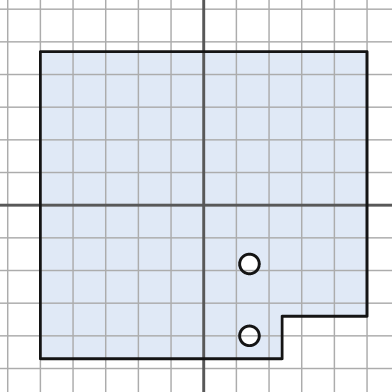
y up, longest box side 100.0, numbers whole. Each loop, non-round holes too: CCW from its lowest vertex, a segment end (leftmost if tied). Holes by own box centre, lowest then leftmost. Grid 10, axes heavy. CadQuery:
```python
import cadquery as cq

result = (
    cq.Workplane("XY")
    .moveTo(-50.0, -47.0)
    .lineTo(24.0, -47.0)
    .lineTo(24.0, -34.0)
    .lineTo(50.0, -34.0)
    .lineTo(50.0, 47.0)
    .lineTo(-50.0, 47.0)
    .close()
    .moveTo(14.0, -40.0)
    .circle(3.0)
    .moveTo(14.0, -18.0)
    .circle(3.0)
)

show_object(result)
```